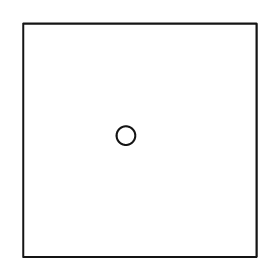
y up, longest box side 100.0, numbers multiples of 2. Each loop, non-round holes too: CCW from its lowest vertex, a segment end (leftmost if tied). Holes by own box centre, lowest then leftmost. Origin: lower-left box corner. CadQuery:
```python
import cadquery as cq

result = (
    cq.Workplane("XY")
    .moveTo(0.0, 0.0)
    .lineTo(100.0, 0.0)
    .lineTo(100.0, 100.0)
    .lineTo(0.0, 100.0)
    .close()
    .moveTo(44.0, 52.0)
    .circle(4.0)
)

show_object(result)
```